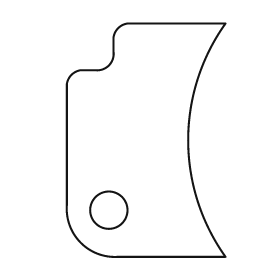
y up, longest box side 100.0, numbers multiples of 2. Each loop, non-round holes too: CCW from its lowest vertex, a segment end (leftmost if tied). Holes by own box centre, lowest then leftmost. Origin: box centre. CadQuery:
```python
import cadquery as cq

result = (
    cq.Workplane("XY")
    .moveTo(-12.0, -50.0)
    .lineTo(34.0, -50.0)
    .threePointArc((18.0, 0.0), (34.0, 50.0))
    .lineTo(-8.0, 50.0)
    .threePointArc((-12.0, 48.0), (-14.0, 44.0))
    .lineTo(-14.0, 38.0)
    .threePointArc((-16.0, 32.0), (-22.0, 30.0))
    .lineTo(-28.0, 30.0)
    .threePointArc((-32.0, 28.0), (-34.0, 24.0))
    .lineTo(-34.0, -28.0)
    .threePointArc((-28.0, -44.0), (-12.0, -50.0))
    .close()
    .moveTo(-16.0, -30.0)
    .circle(8.0)
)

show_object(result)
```